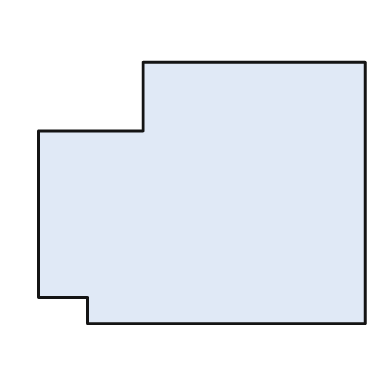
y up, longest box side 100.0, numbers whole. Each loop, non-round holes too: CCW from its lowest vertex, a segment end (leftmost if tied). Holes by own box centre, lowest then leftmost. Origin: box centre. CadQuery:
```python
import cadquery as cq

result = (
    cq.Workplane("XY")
    .moveTo(-35.0, -40.0)
    .lineTo(50.0, -40.0)
    .lineTo(50.0, 40.0)
    .lineTo(-18.0, 40.0)
    .lineTo(-18.0, 19.0)
    .lineTo(-50.0, 19.0)
    .lineTo(-50.0, -32.0)
    .lineTo(-35.0, -32.0)
    .close()
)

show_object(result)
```